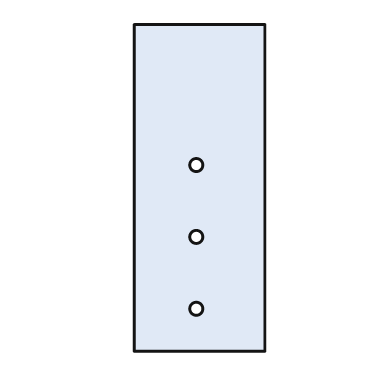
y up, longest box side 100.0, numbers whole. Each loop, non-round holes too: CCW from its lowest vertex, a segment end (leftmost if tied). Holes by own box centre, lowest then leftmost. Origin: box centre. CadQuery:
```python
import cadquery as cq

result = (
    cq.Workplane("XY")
    .moveTo(-20.0, -50.0)
    .lineTo(20.0, -50.0)
    .lineTo(20.0, 50.0)
    .lineTo(-20.0, 50.0)
    .close()
    .moveTo(-1.0, -37.0)
    .circle(2.0)
    .moveTo(-1.0, -15.0)
    .circle(2.0)
    .moveTo(-1.0, 7.0)
    .circle(2.0)
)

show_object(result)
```